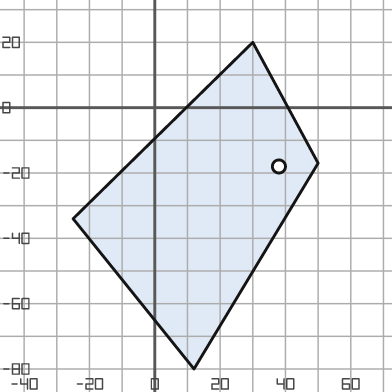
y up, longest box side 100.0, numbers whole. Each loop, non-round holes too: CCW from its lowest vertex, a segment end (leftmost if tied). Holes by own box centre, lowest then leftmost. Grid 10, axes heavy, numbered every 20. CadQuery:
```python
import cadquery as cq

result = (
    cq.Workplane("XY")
    .moveTo(12.0, -80.0)
    .lineTo(50.0, -17.0)
    .lineTo(30.0, 20.0)
    .lineTo(-25.0, -34.0)
    .close()
    .moveTo(38.0, -18.0)
    .circle(2.0)
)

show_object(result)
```